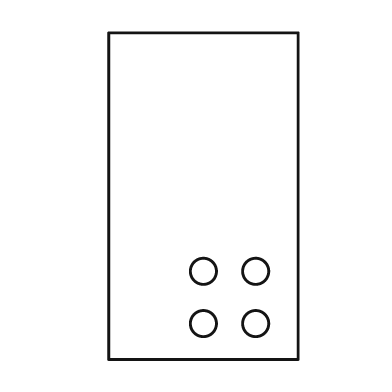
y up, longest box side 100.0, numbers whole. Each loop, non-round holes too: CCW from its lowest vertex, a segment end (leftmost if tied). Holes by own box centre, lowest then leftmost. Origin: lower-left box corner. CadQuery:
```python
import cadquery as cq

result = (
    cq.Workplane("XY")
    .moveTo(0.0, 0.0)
    .lineTo(58.0, 0.0)
    .lineTo(58.0, 100.0)
    .lineTo(0.0, 100.0)
    .close()
    .moveTo(29.0, 11.0)
    .circle(4.0)
    .moveTo(45.0, 11.0)
    .circle(4.0)
    .moveTo(29.0, 27.0)
    .circle(4.0)
    .moveTo(45.0, 27.0)
    .circle(4.0)
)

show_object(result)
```